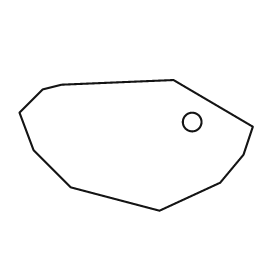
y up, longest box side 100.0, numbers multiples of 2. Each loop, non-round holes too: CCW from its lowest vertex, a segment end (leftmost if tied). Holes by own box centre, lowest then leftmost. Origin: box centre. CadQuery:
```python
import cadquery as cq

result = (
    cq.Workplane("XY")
    .moveTo(10.0, -28.0)
    .lineTo(36.0, -16.0)
    .lineTo(46.0, -4.0)
    .lineTo(50.0, 8.0)
    .lineTo(16.0, 28.0)
    .lineTo(-32.0, 26.0)
    .lineTo(-40.0, 24.0)
    .lineTo(-50.0, 14.0)
    .lineTo(-44.0, -2.0)
    .lineTo(-28.0, -18.0)
    .close()
    .moveTo(24.0, 10.0)
    .circle(4.0)
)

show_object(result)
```